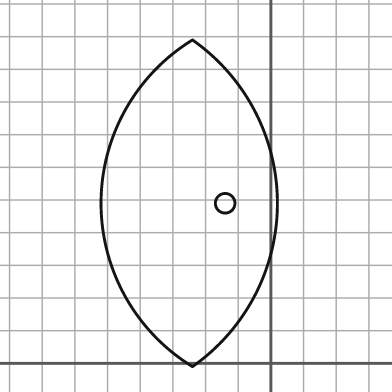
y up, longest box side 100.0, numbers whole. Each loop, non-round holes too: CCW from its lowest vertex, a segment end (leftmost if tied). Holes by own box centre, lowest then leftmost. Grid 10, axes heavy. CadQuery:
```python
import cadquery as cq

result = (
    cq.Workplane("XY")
    .moveTo(-24.0, -1.0)
    .threePointArc((2.0, 49.0), (-24.0, 99.0))
    .threePointArc((-52.0, 49.0), (-24.0, -1.0))
    .close()
    .moveTo(-14.0, 49.0)
    .circle(3.0)
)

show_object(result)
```